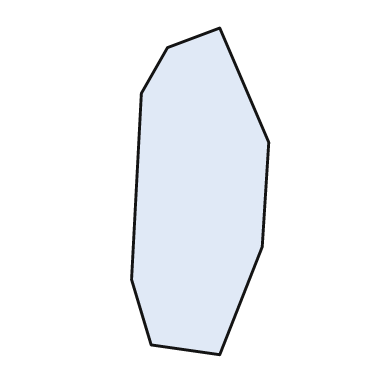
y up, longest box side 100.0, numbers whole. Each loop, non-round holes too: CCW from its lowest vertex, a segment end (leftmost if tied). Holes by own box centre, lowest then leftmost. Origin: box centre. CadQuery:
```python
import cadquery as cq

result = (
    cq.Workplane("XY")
    .moveTo(6.0, -50.0)
    .lineTo(19.0, -17.0)
    .lineTo(21.0, 15.0)
    .lineTo(6.0, 50.0)
    .lineTo(-10.0, 44.0)
    .lineTo(-18.0, 30.0)
    .lineTo(-21.0, -27.0)
    .lineTo(-15.0, -47.0)
    .close()
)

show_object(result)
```